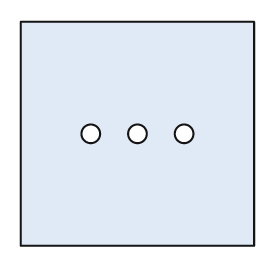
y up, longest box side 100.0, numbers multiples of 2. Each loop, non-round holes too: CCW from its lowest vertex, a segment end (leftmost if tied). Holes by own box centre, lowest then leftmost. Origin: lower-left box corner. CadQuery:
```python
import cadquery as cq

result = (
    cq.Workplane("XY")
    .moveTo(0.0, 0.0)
    .lineTo(100.0, 0.0)
    .lineTo(100.0, 96.0)
    .lineTo(0.0, 96.0)
    .close()
    .moveTo(30.0, 48.0)
    .circle(4.0)
    .moveTo(50.0, 48.0)
    .circle(4.0)
    .moveTo(70.0, 48.0)
    .circle(4.0)
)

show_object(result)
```